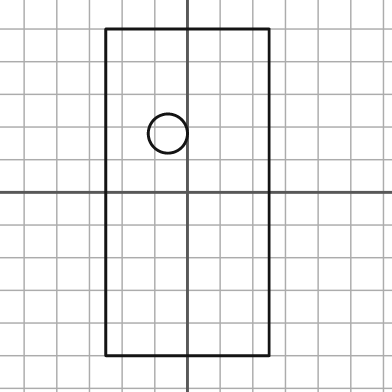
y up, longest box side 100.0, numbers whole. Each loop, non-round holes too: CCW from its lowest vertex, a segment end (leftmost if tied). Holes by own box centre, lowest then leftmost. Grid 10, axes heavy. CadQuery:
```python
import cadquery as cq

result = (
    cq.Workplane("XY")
    .moveTo(-25.0, -50.0)
    .lineTo(25.0, -50.0)
    .lineTo(25.0, 50.0)
    .lineTo(-25.0, 50.0)
    .close()
    .moveTo(-6.0, 18.0)
    .circle(6.0)
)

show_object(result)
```